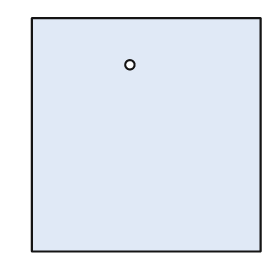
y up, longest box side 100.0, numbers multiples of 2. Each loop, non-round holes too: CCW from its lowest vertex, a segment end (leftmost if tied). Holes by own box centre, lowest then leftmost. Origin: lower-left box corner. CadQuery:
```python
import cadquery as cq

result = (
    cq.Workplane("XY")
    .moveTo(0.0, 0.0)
    .lineTo(98.0, 0.0)
    .lineTo(98.0, 100.0)
    .lineTo(0.0, 100.0)
    .close()
    .moveTo(42.0, 80.0)
    .circle(2.0)
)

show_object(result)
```